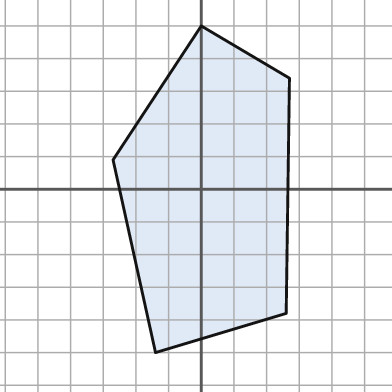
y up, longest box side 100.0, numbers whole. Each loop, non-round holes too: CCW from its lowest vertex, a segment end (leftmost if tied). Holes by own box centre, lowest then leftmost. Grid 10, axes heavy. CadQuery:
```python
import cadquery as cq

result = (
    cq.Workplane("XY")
    .moveTo(-14.0, -50.0)
    .lineTo(26.0, -38.0)
    .lineTo(27.0, 34.0)
    .lineTo(0.0, 50.0)
    .lineTo(-27.0, 9.0)
    .close()
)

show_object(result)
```